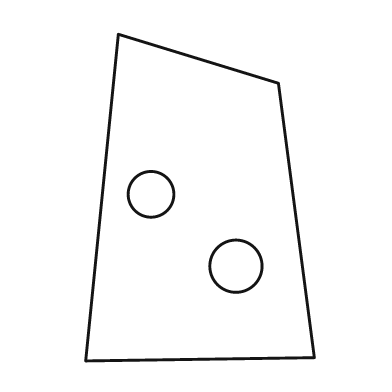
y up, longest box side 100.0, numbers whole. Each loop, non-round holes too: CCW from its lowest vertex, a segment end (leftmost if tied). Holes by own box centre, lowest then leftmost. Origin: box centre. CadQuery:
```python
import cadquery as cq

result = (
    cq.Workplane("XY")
    .moveTo(-35.0, -50.0)
    .lineTo(35.0, -49.0)
    .lineTo(24.0, 35.0)
    .lineTo(-25.0, 50.0)
    .close()
    .moveTo(11.0, -21.0)
    .circle(8.0)
    .moveTo(-15.0, 1.0)
    .circle(7.0)
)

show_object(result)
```